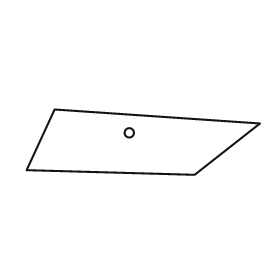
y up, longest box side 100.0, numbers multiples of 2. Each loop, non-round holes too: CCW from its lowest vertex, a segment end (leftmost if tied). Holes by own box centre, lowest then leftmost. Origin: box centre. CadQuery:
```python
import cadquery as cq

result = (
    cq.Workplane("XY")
    .moveTo(22.0, -14.0)
    .lineTo(50.0, 8.0)
    .lineTo(-38.0, 14.0)
    .lineTo(-50.0, -12.0)
    .close()
    .moveTo(-6.0, 4.0)
    .circle(2.0)
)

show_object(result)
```